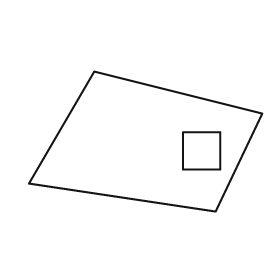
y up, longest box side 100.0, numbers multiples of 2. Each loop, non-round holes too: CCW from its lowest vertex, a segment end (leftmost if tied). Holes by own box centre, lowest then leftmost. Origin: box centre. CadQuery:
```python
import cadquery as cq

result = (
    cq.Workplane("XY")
    .moveTo(30.0, -30.0)
    .lineTo(50.0, 12.0)
    .lineTo(-22.0, 30.0)
    .lineTo(-50.0, -18.0)
    .close()
    .moveTo(16.0, -12.0)
    .lineTo(32.0, -12.0)
    .lineTo(32.0, 4.0)
    .lineTo(16.0, 4.0)
    .close()
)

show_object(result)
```